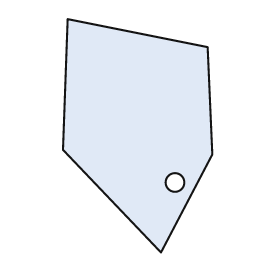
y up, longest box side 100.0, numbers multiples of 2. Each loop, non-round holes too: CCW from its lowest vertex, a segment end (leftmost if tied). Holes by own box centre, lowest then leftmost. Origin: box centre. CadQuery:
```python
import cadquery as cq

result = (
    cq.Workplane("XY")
    .moveTo(10.0, -50.0)
    .lineTo(32.0, -8.0)
    .lineTo(30.0, 38.0)
    .lineTo(-30.0, 50.0)
    .lineTo(-32.0, -6.0)
    .close()
    .moveTo(16.0, -20.0)
    .circle(4.0)
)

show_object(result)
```